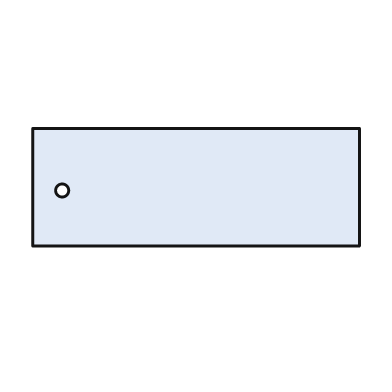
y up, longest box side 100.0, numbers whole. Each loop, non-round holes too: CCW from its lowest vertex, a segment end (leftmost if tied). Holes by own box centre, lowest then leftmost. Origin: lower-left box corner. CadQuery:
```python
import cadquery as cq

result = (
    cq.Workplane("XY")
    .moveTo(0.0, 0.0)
    .lineTo(100.0, 0.0)
    .lineTo(100.0, 36.0)
    .lineTo(0.0, 36.0)
    .close()
    .moveTo(9.0, 17.0)
    .circle(2.0)
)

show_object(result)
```